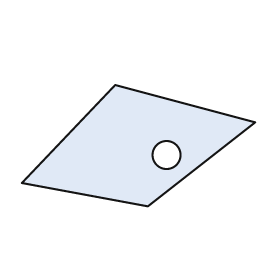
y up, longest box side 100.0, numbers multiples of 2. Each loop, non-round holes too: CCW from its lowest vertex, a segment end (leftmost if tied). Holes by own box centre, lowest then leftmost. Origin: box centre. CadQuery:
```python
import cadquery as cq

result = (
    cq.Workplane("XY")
    .moveTo(4.0, -26.0)
    .lineTo(50.0, 10.0)
    .lineTo(-10.0, 26.0)
    .lineTo(-50.0, -16.0)
    .close()
    .moveTo(12.0, -4.0)
    .circle(6.0)
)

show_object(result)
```